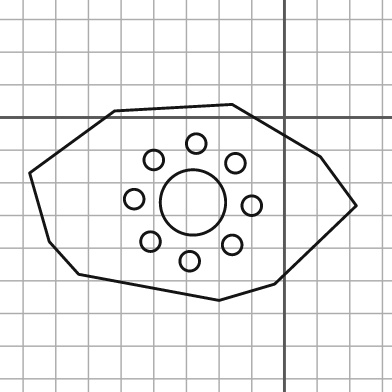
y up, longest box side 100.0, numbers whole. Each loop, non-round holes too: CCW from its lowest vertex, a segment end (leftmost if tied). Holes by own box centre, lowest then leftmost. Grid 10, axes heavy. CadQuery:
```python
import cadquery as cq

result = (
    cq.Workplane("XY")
    .moveTo(-20.0, -56.0)
    .lineTo(-3.0, -51.0)
    .lineTo(22.0, -27.0)
    .lineTo(11.0, -12.0)
    .lineTo(-16.0, 4.0)
    .lineTo(-52.0, 2.0)
    .lineTo(-78.0, -17.0)
    .lineTo(-72.0, -38.0)
    .lineTo(-63.0, -48.0)
    .close()
    .moveTo(-29.0, -44.0)
    .circle(3.0)
    .moveTo(-16.0, -39.0)
    .circle(3.0)
    .moveTo(-41.0, -38.0)
    .circle(3.0)
    .moveTo(-10.0, -27.0)
    .circle(3.0)
    .moveTo(-28.0, -26.0)
    .circle(10.0)
    .moveTo(-46.0, -25.0)
    .circle(3.0)
    .moveTo(-15.0, -14.0)
    .circle(3.0)
    .moveTo(-40.0, -13.0)
    .circle(3.0)
    .moveTo(-27.0, -8.0)
    .circle(3.0)
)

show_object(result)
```